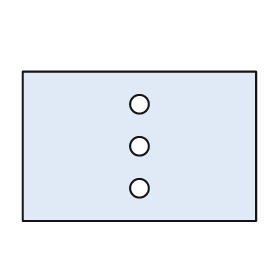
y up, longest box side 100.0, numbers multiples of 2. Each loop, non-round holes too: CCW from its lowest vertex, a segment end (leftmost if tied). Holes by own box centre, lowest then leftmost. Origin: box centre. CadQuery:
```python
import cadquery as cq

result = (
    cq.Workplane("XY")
    .moveTo(-50.0, -32.0)
    .lineTo(50.0, -32.0)
    .lineTo(50.0, 32.0)
    .lineTo(-50.0, 32.0)
    .close()
    .moveTo(0.0, -18.0)
    .circle(4.0)
    .moveTo(0.0, 0.0)
    .circle(4.0)
    .moveTo(0.0, 18.0)
    .circle(4.0)
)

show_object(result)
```